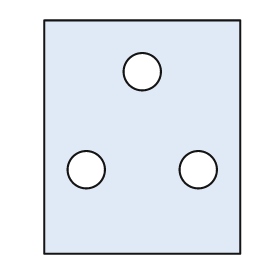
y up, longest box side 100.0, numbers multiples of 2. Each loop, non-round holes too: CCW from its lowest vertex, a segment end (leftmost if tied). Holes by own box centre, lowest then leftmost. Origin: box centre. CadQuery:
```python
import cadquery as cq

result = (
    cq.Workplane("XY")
    .moveTo(-42.0, -50.0)
    .lineTo(42.0, -50.0)
    .lineTo(42.0, 50.0)
    .lineTo(-42.0, 50.0)
    .close()
    .moveTo(-24.0, -14.0)
    .circle(8.0)
    .moveTo(24.0, -14.0)
    .circle(8.0)
    .moveTo(0.0, 28.0)
    .circle(8.0)
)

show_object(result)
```